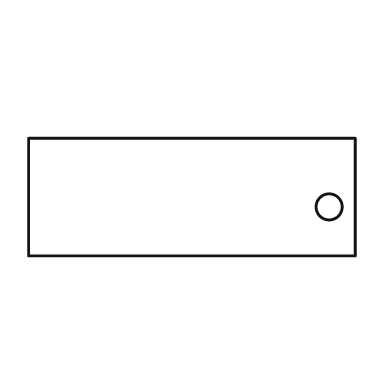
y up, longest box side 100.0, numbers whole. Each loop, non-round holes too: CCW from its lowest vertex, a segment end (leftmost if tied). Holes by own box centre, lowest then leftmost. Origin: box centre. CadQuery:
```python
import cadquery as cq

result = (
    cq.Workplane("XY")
    .moveTo(-50.0, -18.0)
    .lineTo(50.0, -18.0)
    .lineTo(50.0, 18.0)
    .lineTo(-50.0, 18.0)
    .close()
    .moveTo(42.0, -3.0)
    .circle(4.0)
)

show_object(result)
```